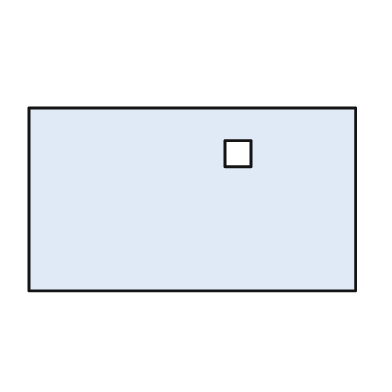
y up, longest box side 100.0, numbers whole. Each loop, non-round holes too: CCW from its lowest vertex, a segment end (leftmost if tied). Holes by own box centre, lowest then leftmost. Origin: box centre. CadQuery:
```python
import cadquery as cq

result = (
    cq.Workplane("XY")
    .moveTo(-50.0, -28.0)
    .lineTo(50.0, -28.0)
    .lineTo(50.0, 28.0)
    .lineTo(-50.0, 28.0)
    .close()
    .moveTo(10.0, 10.0)
    .lineTo(18.0, 10.0)
    .lineTo(18.0, 18.0)
    .lineTo(10.0, 18.0)
    .close()
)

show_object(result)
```